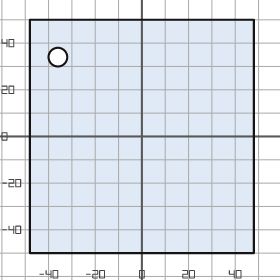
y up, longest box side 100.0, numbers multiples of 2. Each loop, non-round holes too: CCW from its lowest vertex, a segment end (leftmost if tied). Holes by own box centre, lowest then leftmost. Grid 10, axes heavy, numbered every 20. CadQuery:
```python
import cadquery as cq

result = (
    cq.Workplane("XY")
    .moveTo(-48.0, -50.0)
    .lineTo(48.0, -50.0)
    .lineTo(48.0, 50.0)
    .lineTo(-48.0, 50.0)
    .close()
    .moveTo(-36.0, 34.0)
    .circle(4.0)
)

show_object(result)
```